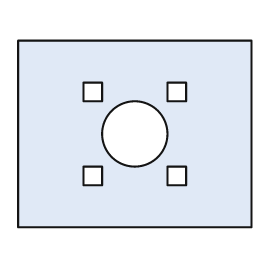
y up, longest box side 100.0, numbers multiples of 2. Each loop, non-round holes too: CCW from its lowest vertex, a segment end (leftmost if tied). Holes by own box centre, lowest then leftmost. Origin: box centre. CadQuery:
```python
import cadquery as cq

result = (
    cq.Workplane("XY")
    .moveTo(-50.0, -40.0)
    .lineTo(50.0, -40.0)
    .lineTo(50.0, 40.0)
    .lineTo(-50.0, 40.0)
    .close()
    .moveTo(-22.0, -22.0)
    .lineTo(-14.0, -22.0)
    .lineTo(-14.0, -14.0)
    .lineTo(-22.0, -14.0)
    .close()
    .moveTo(14.0, -22.0)
    .lineTo(22.0, -22.0)
    .lineTo(22.0, -14.0)
    .lineTo(14.0, -14.0)
    .close()
    .moveTo(0.0, 0.0)
    .circle(14.0)
    .moveTo(-22.0, 14.0)
    .lineTo(-14.0, 14.0)
    .lineTo(-14.0, 22.0)
    .lineTo(-22.0, 22.0)
    .close()
    .moveTo(14.0, 14.0)
    .lineTo(22.0, 14.0)
    .lineTo(22.0, 22.0)
    .lineTo(14.0, 22.0)
    .close()
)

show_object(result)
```